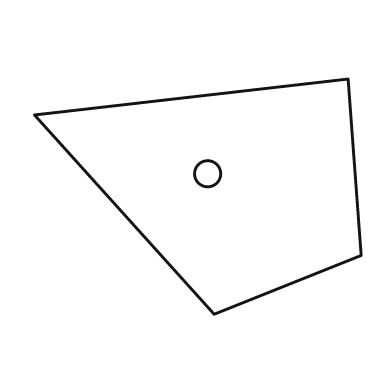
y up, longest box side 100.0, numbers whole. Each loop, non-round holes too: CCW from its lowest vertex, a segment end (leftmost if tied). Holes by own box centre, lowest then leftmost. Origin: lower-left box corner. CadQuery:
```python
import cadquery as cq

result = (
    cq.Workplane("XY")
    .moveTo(55.0, 0.0)
    .lineTo(100.0, 18.0)
    .lineTo(96.0, 72.0)
    .lineTo(0.0, 61.0)
    .close()
    .moveTo(53.0, 43.0)
    .circle(4.0)
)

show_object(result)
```